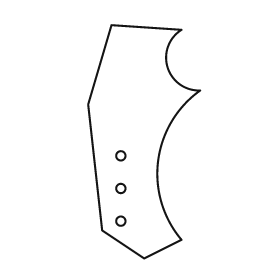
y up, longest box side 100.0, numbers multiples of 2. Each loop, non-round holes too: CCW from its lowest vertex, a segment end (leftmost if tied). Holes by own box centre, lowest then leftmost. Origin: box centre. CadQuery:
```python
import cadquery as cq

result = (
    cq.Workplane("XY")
    .moveTo(0.0, -50.0)
    .lineTo(16.0, -42.0)
    .threePointArc((6.0, -8.0), (24.0, 22.0))
    .threePointArc((10.0, 32.0), (16.0, 48.0))
    .lineTo(-14.0, 50.0)
    .lineTo(-24.0, 16.0)
    .lineTo(-18.0, -38.0)
    .close()
    .moveTo(-10.0, -34.0)
    .circle(2.0)
    .moveTo(-10.0, -20.0)
    .circle(2.0)
    .moveTo(-10.0, -6.0)
    .circle(2.0)
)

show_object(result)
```